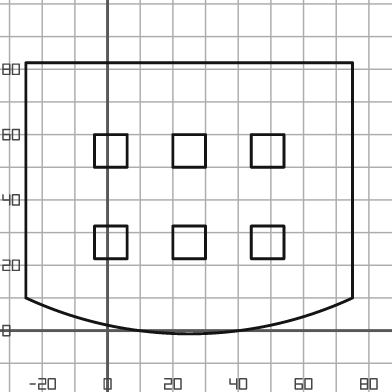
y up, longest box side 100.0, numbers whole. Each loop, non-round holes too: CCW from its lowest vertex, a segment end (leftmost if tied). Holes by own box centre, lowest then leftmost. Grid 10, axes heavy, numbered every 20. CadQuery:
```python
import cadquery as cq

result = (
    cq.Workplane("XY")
    .moveTo(-25.0, 10.0)
    .threePointArc((25.0, -1.0), (75.0, 10.0))
    .lineTo(75.0, 82.0)
    .lineTo(-25.0, 82.0)
    .close()
    .moveTo(-4.0, 22.0)
    .lineTo(6.0, 22.0)
    .lineTo(6.0, 32.0)
    .lineTo(-4.0, 32.0)
    .close()
    .moveTo(20.0, 22.0)
    .lineTo(30.0, 22.0)
    .lineTo(30.0, 32.0)
    .lineTo(20.0, 32.0)
    .close()
    .moveTo(44.0, 22.0)
    .lineTo(54.0, 22.0)
    .lineTo(54.0, 32.0)
    .lineTo(44.0, 32.0)
    .close()
    .moveTo(-4.0, 50.0)
    .lineTo(6.0, 50.0)
    .lineTo(6.0, 60.0)
    .lineTo(-4.0, 60.0)
    .close()
    .moveTo(20.0, 50.0)
    .lineTo(30.0, 50.0)
    .lineTo(30.0, 60.0)
    .lineTo(20.0, 60.0)
    .close()
    .moveTo(44.0, 50.0)
    .lineTo(54.0, 50.0)
    .lineTo(54.0, 60.0)
    .lineTo(44.0, 60.0)
    .close()
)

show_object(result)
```